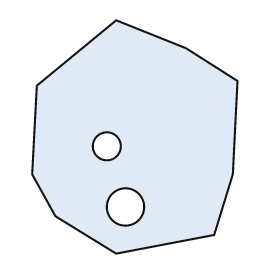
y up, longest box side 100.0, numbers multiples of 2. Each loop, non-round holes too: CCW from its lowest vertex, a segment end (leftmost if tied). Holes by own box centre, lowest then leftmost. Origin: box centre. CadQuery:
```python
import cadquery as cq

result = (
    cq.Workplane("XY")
    .moveTo(-8.0, -50.0)
    .lineTo(34.0, -42.0)
    .lineTo(42.0, -16.0)
    .lineTo(44.0, 24.0)
    .lineTo(22.0, 38.0)
    .lineTo(-8.0, 50.0)
    .lineTo(-42.0, 22.0)
    .lineTo(-44.0, -16.0)
    .lineTo(-34.0, -34.0)
    .close()
    .moveTo(-4.0, -30.0)
    .circle(8.0)
    .moveTo(-12.0, -4.0)
    .circle(6.0)
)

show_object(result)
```